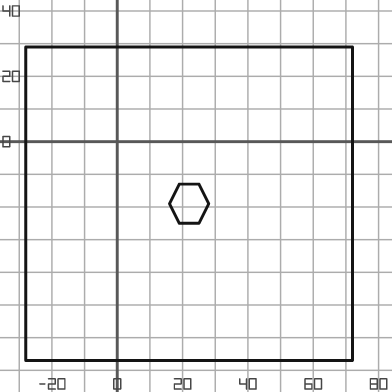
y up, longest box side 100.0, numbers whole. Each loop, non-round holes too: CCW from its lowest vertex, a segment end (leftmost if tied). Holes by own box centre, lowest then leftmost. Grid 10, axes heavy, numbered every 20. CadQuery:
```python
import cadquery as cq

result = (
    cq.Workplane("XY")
    .moveTo(-28.0, -67.0)
    .lineTo(72.0, -67.0)
    .lineTo(72.0, 29.0)
    .lineTo(-28.0, 29.0)
    .close()
    .moveTo(19.0, -25.0)
    .lineTo(25.0, -25.0)
    .lineTo(28.0, -19.0)
    .lineTo(25.0, -13.0)
    .lineTo(19.0, -13.0)
    .lineTo(16.0, -19.0)
    .close()
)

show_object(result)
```